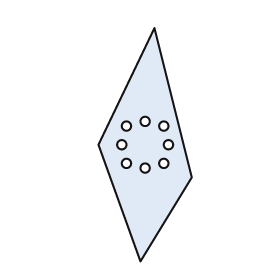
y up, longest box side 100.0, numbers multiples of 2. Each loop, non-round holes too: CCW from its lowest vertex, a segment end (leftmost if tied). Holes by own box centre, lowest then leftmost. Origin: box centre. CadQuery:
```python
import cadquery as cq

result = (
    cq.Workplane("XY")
    .moveTo(-2.0, -50.0)
    .lineTo(20.0, -14.0)
    .lineTo(4.0, 50.0)
    .lineTo(-20.0, 0.0)
    .close()
    .moveTo(0.0, -10.0)
    .circle(2.0)
    .moveTo(-8.0, -8.0)
    .circle(2.0)
    .moveTo(8.0, -8.0)
    .circle(2.0)
    .moveTo(-10.0, 0.0)
    .circle(2.0)
    .moveTo(10.0, 0.0)
    .circle(2.0)
    .moveTo(-8.0, 8.0)
    .circle(2.0)
    .moveTo(8.0, 8.0)
    .circle(2.0)
    .moveTo(0.0, 10.0)
    .circle(2.0)
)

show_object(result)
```